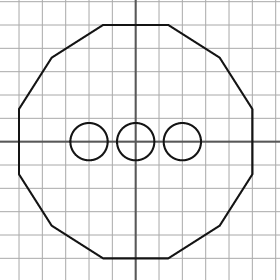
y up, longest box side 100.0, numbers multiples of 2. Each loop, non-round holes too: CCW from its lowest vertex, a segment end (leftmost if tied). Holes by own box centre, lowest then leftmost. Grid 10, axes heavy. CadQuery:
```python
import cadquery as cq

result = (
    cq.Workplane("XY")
    .moveTo(-14.0, -50.0)
    .lineTo(14.0, -50.0)
    .lineTo(36.0, -36.0)
    .lineTo(50.0, -14.0)
    .lineTo(50.0, 14.0)
    .lineTo(36.0, 36.0)
    .lineTo(14.0, 50.0)
    .lineTo(-14.0, 50.0)
    .lineTo(-36.0, 36.0)
    .lineTo(-50.0, 14.0)
    .lineTo(-50.0, -14.0)
    .lineTo(-36.0, -36.0)
    .close()
    .moveTo(-20.0, 0.0)
    .circle(8.0)
    .moveTo(0.0, 0.0)
    .circle(8.0)
    .moveTo(20.0, 0.0)
    .circle(8.0)
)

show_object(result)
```